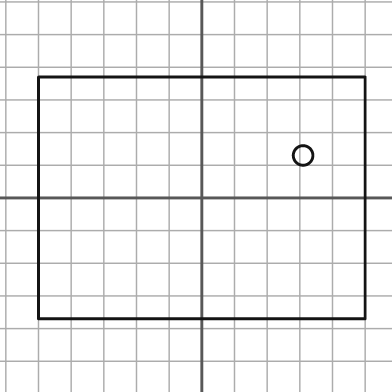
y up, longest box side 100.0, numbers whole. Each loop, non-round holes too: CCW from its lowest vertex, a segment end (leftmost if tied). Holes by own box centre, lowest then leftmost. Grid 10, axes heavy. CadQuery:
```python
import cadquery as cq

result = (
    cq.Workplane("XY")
    .moveTo(-50.0, -37.0)
    .lineTo(50.0, -37.0)
    .lineTo(50.0, 37.0)
    .lineTo(-50.0, 37.0)
    .close()
    .moveTo(31.0, 13.0)
    .circle(3.0)
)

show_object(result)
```